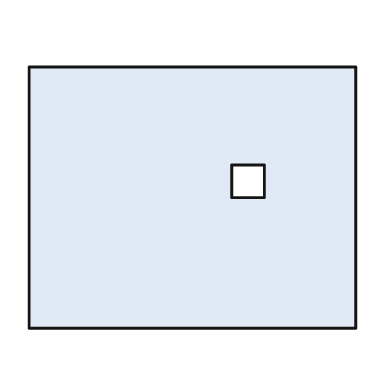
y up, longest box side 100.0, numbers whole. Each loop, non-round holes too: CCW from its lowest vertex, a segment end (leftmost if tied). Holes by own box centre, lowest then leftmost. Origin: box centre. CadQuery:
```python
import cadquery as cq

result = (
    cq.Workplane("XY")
    .moveTo(-50.0, -40.0)
    .lineTo(50.0, -40.0)
    .lineTo(50.0, 40.0)
    .lineTo(-50.0, 40.0)
    .close()
    .moveTo(12.0, 0.0)
    .lineTo(22.0, 0.0)
    .lineTo(22.0, 10.0)
    .lineTo(12.0, 10.0)
    .close()
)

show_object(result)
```